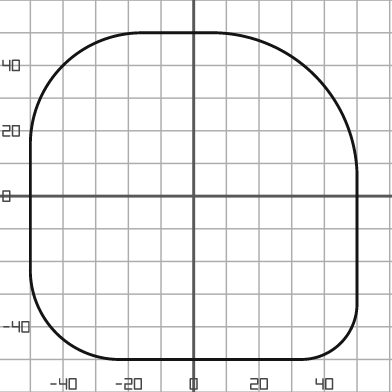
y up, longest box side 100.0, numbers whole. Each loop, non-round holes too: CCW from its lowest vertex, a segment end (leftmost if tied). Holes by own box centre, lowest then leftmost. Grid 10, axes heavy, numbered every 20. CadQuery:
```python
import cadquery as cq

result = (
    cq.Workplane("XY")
    .moveTo(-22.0, -50.0)
    .lineTo(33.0, -50.0)
    .threePointArc((45.0, -45.0), (50.0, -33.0))
    .lineTo(50.0, 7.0)
    .threePointArc((37.0, 37.0), (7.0, 50.0))
    .lineTo(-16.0, 50.0)
    .threePointArc((-40.0, 40.0), (-50.0, 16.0))
    .lineTo(-50.0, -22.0)
    .threePointArc((-42.0, -42.0), (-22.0, -50.0))
    .close()
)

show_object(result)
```